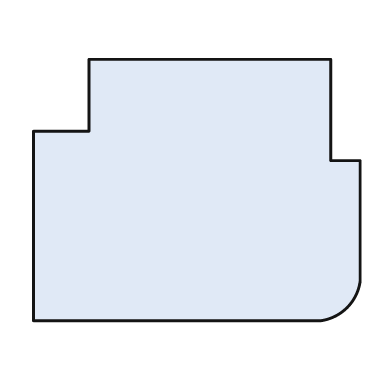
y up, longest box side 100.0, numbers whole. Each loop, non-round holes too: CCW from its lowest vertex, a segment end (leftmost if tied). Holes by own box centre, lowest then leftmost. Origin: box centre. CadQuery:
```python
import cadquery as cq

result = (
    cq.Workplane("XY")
    .moveTo(-50.0, -40.0)
    .lineTo(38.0, -40.0)
    .threePointArc((46.0, -36.0), (50.0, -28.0))
    .lineTo(50.0, 9.0)
    .lineTo(41.0, 9.0)
    .lineTo(41.0, 40.0)
    .lineTo(-33.0, 40.0)
    .lineTo(-33.0, 18.0)
    .lineTo(-50.0, 18.0)
    .close()
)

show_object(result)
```